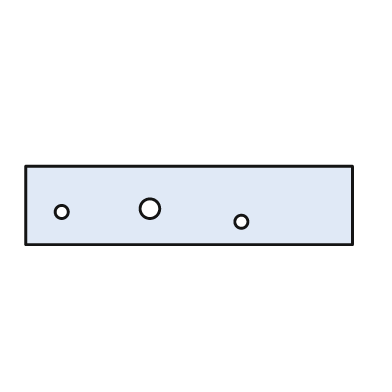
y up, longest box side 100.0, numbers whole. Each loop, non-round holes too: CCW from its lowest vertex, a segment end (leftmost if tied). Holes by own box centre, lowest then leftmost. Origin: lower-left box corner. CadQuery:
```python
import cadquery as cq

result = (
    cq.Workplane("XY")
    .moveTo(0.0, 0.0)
    .lineTo(100.0, 0.0)
    .lineTo(100.0, 24.0)
    .lineTo(0.0, 24.0)
    .close()
    .moveTo(66.0, 7.0)
    .circle(2.0)
    .moveTo(11.0, 10.0)
    .circle(2.0)
    .moveTo(38.0, 11.0)
    .circle(3.0)
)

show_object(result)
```